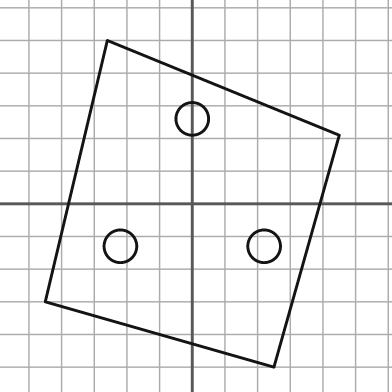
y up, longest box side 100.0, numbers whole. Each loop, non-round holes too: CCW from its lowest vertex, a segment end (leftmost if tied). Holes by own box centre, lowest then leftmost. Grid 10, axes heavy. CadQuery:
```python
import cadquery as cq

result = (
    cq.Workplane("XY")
    .moveTo(25.0, -50.0)
    .lineTo(45.0, 21.0)
    .lineTo(-26.0, 50.0)
    .lineTo(-45.0, -30.0)
    .close()
    .moveTo(-22.0, -13.0)
    .circle(5.0)
    .moveTo(22.0, -13.0)
    .circle(5.0)
    .moveTo(0.0, 26.0)
    .circle(5.0)
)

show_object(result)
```